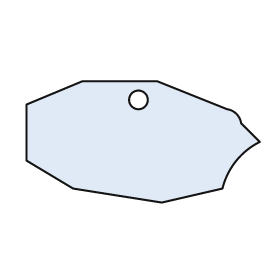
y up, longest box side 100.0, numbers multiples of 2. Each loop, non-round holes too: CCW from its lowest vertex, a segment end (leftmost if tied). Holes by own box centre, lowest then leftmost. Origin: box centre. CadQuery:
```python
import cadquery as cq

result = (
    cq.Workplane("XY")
    .moveTo(8.0, -26.0)
    .lineTo(34.0, -20.0)
    .threePointArc((40.0, -8.0), (50.0, 0.0))
    .lineTo(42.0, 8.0)
    .threePointArc((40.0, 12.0), (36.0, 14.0))
    .lineTo(6.0, 26.0)
    .lineTo(-26.0, 26.0)
    .lineTo(-50.0, 16.0)
    .lineTo(-50.0, -8.0)
    .lineTo(-30.0, -20.0)
    .close()
    .moveTo(-2.0, 18.0)
    .circle(4.0)
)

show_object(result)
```